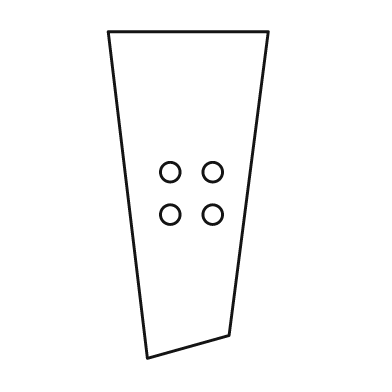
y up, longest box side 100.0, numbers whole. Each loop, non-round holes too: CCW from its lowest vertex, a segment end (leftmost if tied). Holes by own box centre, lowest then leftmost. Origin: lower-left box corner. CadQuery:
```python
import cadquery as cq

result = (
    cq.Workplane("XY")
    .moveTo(12.0, 0.0)
    .lineTo(37.0, 7.0)
    .lineTo(49.0, 100.0)
    .lineTo(0.0, 100.0)
    .close()
    .moveTo(19.0, 44.0)
    .circle(3.0)
    .moveTo(32.0, 44.0)
    .circle(3.0)
    .moveTo(19.0, 57.0)
    .circle(3.0)
    .moveTo(32.0, 57.0)
    .circle(3.0)
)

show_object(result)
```